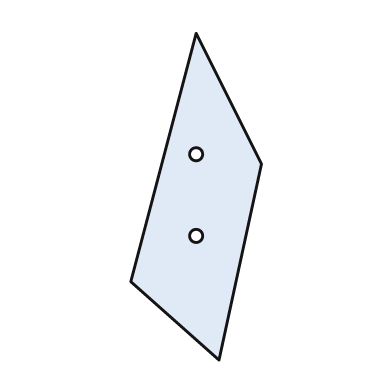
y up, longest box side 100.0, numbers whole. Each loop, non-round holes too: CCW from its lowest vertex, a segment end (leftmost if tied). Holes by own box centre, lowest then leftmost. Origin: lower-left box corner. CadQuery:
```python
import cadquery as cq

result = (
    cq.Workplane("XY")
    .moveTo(27.0, 0.0)
    .lineTo(40.0, 60.0)
    .lineTo(20.0, 100.0)
    .lineTo(0.0, 24.0)
    .close()
    .moveTo(20.0, 38.0)
    .circle(2.0)
    .moveTo(20.0, 63.0)
    .circle(2.0)
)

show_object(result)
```